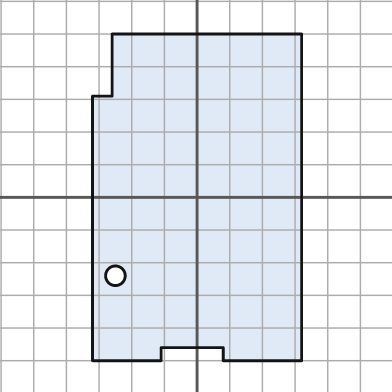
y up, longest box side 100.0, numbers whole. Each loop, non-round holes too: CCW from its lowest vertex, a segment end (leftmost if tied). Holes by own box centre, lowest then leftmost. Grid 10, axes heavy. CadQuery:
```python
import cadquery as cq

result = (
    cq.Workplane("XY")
    .moveTo(-32.0, -50.0)
    .lineTo(-11.0, -50.0)
    .lineTo(-11.0, -46.0)
    .lineTo(8.0, -46.0)
    .lineTo(8.0, -50.0)
    .lineTo(32.0, -50.0)
    .lineTo(32.0, 50.0)
    .lineTo(-26.0, 50.0)
    .lineTo(-26.0, 31.0)
    .lineTo(-32.0, 31.0)
    .close()
    .moveTo(-25.0, -24.0)
    .circle(3.0)
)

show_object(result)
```